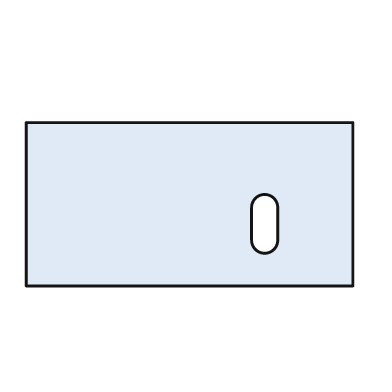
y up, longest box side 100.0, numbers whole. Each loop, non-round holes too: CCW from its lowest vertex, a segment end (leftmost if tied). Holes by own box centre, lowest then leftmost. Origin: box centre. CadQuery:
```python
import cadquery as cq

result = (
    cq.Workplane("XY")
    .moveTo(-50.0, -25.0)
    .lineTo(50.0, -25.0)
    .lineTo(50.0, 25.0)
    .lineTo(-50.0, 25.0)
    .close()
    .moveTo(19.0, -11.0)
    .threePointArc((23.0, -15.0), (27.0, -11.0))
    .lineTo(27.0, -1.0)
    .threePointArc((23.0, 3.0), (19.0, -1.0))
    .close()
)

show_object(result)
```